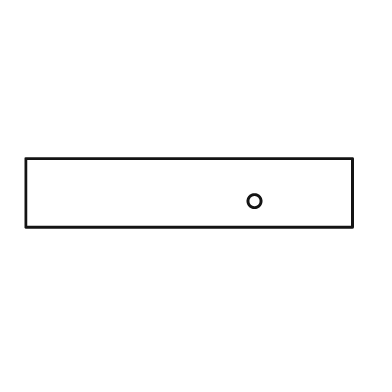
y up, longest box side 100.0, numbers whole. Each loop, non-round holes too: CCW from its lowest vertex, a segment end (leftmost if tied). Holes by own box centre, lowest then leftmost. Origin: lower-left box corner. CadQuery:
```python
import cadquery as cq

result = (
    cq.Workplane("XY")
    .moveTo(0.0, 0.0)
    .lineTo(100.0, 0.0)
    .lineTo(100.0, 21.0)
    .lineTo(0.0, 21.0)
    .close()
    .moveTo(70.0, 8.0)
    .circle(2.0)
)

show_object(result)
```